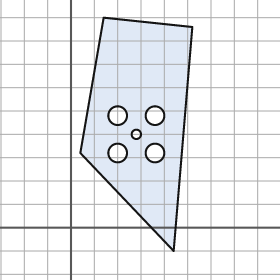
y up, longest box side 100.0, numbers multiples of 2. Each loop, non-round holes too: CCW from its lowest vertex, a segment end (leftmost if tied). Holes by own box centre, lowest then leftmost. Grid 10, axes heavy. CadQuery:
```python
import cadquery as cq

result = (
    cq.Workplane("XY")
    .moveTo(44.0, -10.0)
    .lineTo(52.0, 86.0)
    .lineTo(14.0, 90.0)
    .lineTo(4.0, 32.0)
    .close()
    .moveTo(20.0, 32.0)
    .circle(4.0)
    .moveTo(36.0, 32.0)
    .circle(4.0)
    .moveTo(28.0, 40.0)
    .circle(2.0)
    .moveTo(20.0, 48.0)
    .circle(4.0)
    .moveTo(36.0, 48.0)
    .circle(4.0)
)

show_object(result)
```